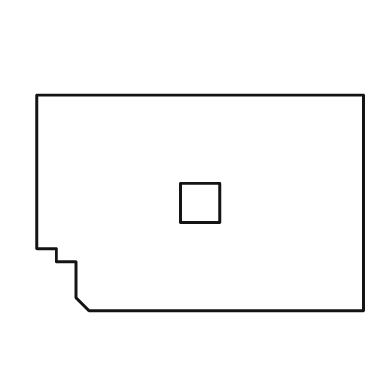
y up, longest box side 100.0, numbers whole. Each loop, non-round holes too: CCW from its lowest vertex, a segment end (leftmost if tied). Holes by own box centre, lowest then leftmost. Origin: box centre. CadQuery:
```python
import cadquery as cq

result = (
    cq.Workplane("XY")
    .moveTo(-34.0, -33.0)
    .lineTo(50.0, -33.0)
    .lineTo(50.0, 33.0)
    .lineTo(-50.0, 33.0)
    .lineTo(-50.0, -14.0)
    .lineTo(-44.0, -14.0)
    .lineTo(-44.0, -18.0)
    .lineTo(-38.0, -18.0)
    .lineTo(-38.0, -29.0)
    .close()
    .moveTo(-6.0, -6.0)
    .lineTo(6.0, -6.0)
    .lineTo(6.0, 6.0)
    .lineTo(-6.0, 6.0)
    .close()
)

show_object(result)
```